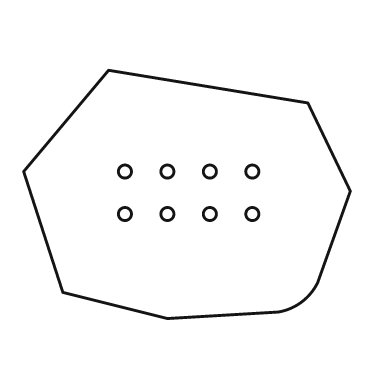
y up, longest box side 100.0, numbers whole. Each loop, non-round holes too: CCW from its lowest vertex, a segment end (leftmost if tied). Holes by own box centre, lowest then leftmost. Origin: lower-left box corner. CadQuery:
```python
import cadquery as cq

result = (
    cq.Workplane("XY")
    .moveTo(44.0, 0.0)
    .lineTo(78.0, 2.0)
    .threePointArc((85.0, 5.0), (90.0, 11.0))
    .lineTo(100.0, 39.0)
    .lineTo(87.0, 66.0)
    .lineTo(26.0, 76.0)
    .lineTo(0.0, 45.0)
    .lineTo(12.0, 8.0)
    .close()
    .moveTo(31.0, 32.0)
    .circle(2.0)
    .moveTo(44.0, 32.0)
    .circle(2.0)
    .moveTo(57.0, 32.0)
    .circle(2.0)
    .moveTo(70.0, 32.0)
    .circle(2.0)
    .moveTo(31.0, 45.0)
    .circle(2.0)
    .moveTo(44.0, 45.0)
    .circle(2.0)
    .moveTo(57.0, 45.0)
    .circle(2.0)
    .moveTo(70.0, 45.0)
    .circle(2.0)
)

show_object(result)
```